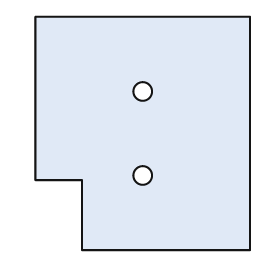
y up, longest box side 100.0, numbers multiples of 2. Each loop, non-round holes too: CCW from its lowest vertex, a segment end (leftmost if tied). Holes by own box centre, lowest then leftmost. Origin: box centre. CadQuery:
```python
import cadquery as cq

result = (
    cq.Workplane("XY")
    .moveTo(-26.0, -50.0)
    .lineTo(46.0, -50.0)
    .lineTo(46.0, 50.0)
    .lineTo(-46.0, 50.0)
    .lineTo(-46.0, -20.0)
    .lineTo(-26.0, -20.0)
    .close()
    .moveTo(0.0, -18.0)
    .circle(4.0)
    .moveTo(0.0, 18.0)
    .circle(4.0)
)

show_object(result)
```